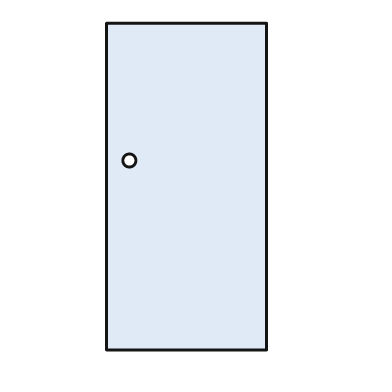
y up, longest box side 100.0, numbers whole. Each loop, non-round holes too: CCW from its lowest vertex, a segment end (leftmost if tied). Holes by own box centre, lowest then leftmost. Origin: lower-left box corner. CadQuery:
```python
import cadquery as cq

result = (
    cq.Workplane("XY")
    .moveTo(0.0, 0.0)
    .lineTo(49.0, 0.0)
    .lineTo(49.0, 100.0)
    .lineTo(0.0, 100.0)
    .close()
    .moveTo(7.0, 58.0)
    .circle(2.0)
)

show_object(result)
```